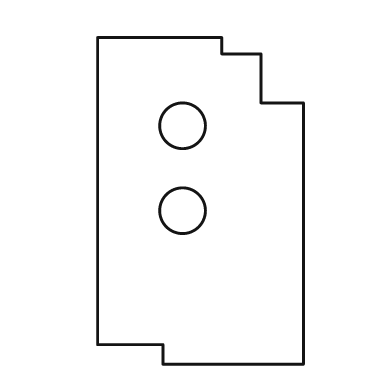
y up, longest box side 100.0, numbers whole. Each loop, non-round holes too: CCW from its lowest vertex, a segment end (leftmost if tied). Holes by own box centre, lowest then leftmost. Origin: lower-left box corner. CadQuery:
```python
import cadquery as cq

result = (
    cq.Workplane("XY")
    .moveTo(20.0, 0.0)
    .lineTo(63.0, 0.0)
    .lineTo(63.0, 80.0)
    .lineTo(50.0, 80.0)
    .lineTo(50.0, 95.0)
    .lineTo(38.0, 95.0)
    .lineTo(38.0, 100.0)
    .lineTo(0.0, 100.0)
    .lineTo(0.0, 6.0)
    .lineTo(20.0, 6.0)
    .close()
    .moveTo(26.0, 47.0)
    .circle(7.0)
    .moveTo(26.0, 73.0)
    .circle(7.0)
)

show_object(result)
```